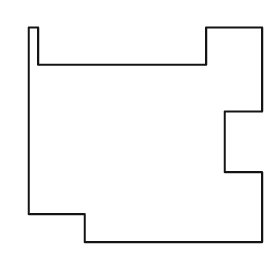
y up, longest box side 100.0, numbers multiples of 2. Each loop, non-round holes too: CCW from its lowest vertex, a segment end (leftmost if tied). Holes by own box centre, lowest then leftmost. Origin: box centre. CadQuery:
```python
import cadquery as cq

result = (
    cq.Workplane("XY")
    .moveTo(-26.0, -46.0)
    .lineTo(50.0, -46.0)
    .lineTo(50.0, -16.0)
    .lineTo(34.0, -16.0)
    .lineTo(34.0, 10.0)
    .lineTo(50.0, 10.0)
    .lineTo(50.0, 46.0)
    .lineTo(26.0, 46.0)
    .lineTo(26.0, 30.0)
    .lineTo(-46.0, 30.0)
    .lineTo(-46.0, 46.0)
    .lineTo(-50.0, 46.0)
    .lineTo(-50.0, -34.0)
    .lineTo(-26.0, -34.0)
    .close()
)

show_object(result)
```